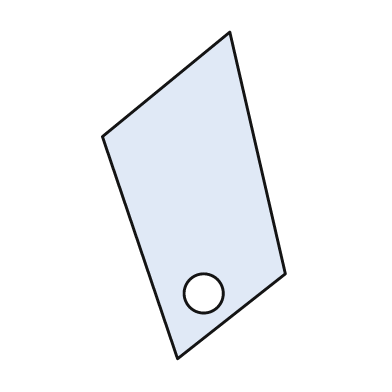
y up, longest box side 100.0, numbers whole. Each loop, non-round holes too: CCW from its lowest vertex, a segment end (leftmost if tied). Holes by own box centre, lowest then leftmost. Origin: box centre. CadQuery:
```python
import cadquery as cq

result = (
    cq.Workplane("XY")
    .moveTo(-5.0, -50.0)
    .lineTo(28.0, -24.0)
    .lineTo(11.0, 50.0)
    .lineTo(-28.0, 18.0)
    .close()
    .moveTo(3.0, -30.0)
    .circle(6.0)
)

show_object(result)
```